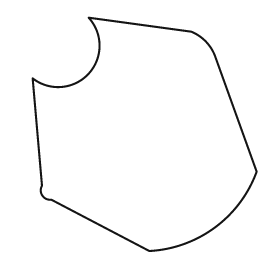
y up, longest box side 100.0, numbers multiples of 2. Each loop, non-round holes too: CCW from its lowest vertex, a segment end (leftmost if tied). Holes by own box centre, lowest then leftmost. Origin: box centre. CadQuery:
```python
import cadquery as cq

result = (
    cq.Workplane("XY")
    .moveTo(2.0, -50.0)
    .threePointArc((30.0, -40.0), (48.0, -16.0))
    .lineTo(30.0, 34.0)
    .threePointArc((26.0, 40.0), (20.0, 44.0))
    .lineTo(-24.0, 50.0)
    .threePointArc((-24.0, 26.0), (-48.0, 24.0))
    .lineTo(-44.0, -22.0)
    .threePointArc((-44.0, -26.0), (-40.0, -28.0))
    .close()
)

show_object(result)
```